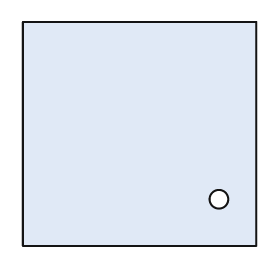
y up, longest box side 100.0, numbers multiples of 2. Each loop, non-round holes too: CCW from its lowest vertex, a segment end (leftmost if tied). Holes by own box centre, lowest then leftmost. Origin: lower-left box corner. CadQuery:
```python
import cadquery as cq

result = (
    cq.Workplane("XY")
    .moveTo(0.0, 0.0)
    .lineTo(100.0, 0.0)
    .lineTo(100.0, 96.0)
    .lineTo(0.0, 96.0)
    .close()
    .moveTo(84.0, 20.0)
    .circle(4.0)
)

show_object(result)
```